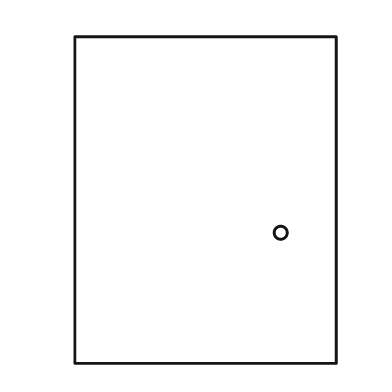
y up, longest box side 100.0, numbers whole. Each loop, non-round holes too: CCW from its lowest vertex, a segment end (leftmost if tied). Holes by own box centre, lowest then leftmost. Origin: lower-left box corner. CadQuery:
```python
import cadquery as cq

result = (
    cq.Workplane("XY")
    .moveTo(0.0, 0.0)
    .lineTo(80.0, 0.0)
    .lineTo(80.0, 100.0)
    .lineTo(0.0, 100.0)
    .close()
    .moveTo(63.0, 40.0)
    .circle(2.0)
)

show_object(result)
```